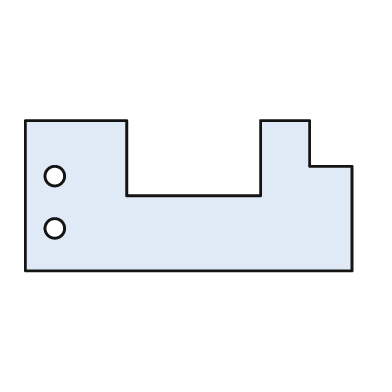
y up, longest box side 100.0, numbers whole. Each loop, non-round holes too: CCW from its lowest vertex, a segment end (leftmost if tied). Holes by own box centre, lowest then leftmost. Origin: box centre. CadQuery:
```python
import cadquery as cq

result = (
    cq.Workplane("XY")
    .moveTo(-50.0, -23.0)
    .lineTo(50.0, -23.0)
    .lineTo(50.0, 9.0)
    .lineTo(37.0, 9.0)
    .lineTo(37.0, 23.0)
    .lineTo(22.0, 23.0)
    .lineTo(22.0, 0.0)
    .lineTo(-19.0, 0.0)
    .lineTo(-19.0, 23.0)
    .lineTo(-50.0, 23.0)
    .close()
    .moveTo(-41.0, -10.0)
    .circle(3.0)
    .moveTo(-41.0, 6.0)
    .circle(3.0)
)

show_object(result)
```